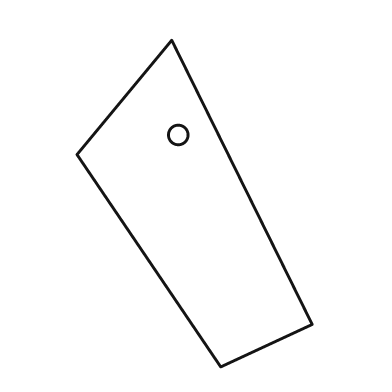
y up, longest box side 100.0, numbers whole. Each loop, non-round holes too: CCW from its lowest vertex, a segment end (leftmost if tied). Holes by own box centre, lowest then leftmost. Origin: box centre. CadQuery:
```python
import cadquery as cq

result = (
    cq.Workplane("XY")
    .moveTo(8.0, -50.0)
    .lineTo(36.0, -37.0)
    .lineTo(-7.0, 50.0)
    .lineTo(-36.0, 15.0)
    .close()
    .moveTo(-5.0, 21.0)
    .circle(3.0)
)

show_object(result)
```